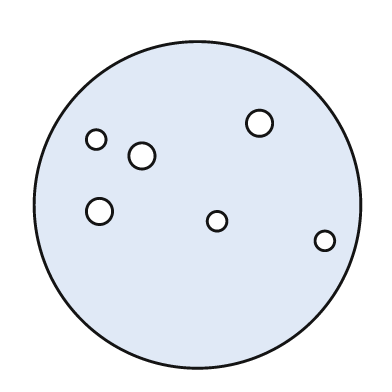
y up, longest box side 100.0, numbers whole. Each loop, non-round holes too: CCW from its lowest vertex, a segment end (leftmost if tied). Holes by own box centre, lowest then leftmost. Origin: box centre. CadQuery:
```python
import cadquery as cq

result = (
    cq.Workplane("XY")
    .moveTo(0.0, 0.0)
    .circle(50.0)
    .moveTo(39.0, -11.0)
    .circle(3.0)
    .moveTo(6.0, -5.0)
    .circle(3.0)
    .moveTo(-30.0, -2.0)
    .circle(4.0)
    .moveTo(-17.0, 15.0)
    .circle(4.0)
    .moveTo(-31.0, 20.0)
    .circle(3.0)
    .moveTo(19.0, 25.0)
    .circle(4.0)
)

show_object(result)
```